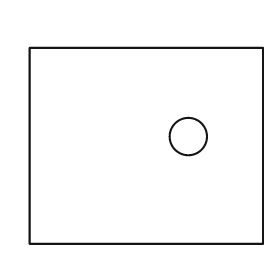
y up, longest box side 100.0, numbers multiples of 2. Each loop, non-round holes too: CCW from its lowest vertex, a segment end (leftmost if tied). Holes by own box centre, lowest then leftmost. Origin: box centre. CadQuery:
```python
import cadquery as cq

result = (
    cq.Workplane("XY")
    .moveTo(-50.0, -42.0)
    .lineTo(50.0, -42.0)
    .lineTo(50.0, 42.0)
    .lineTo(-50.0, 42.0)
    .close()
    .moveTo(18.0, 4.0)
    .circle(8.0)
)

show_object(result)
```